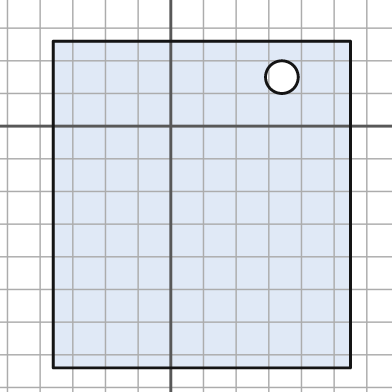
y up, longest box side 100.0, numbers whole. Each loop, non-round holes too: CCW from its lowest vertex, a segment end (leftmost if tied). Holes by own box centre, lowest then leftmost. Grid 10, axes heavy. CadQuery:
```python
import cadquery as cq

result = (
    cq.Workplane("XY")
    .moveTo(-36.0, -74.0)
    .lineTo(55.0, -74.0)
    .lineTo(55.0, 26.0)
    .lineTo(-36.0, 26.0)
    .close()
    .moveTo(34.0, 15.0)
    .circle(5.0)
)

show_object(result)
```